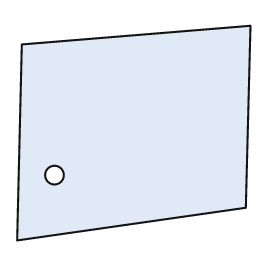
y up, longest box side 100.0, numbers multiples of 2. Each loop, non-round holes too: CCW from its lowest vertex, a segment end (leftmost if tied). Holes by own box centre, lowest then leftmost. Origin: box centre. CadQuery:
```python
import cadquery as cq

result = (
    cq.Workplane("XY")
    .moveTo(-50.0, -46.0)
    .lineTo(48.0, -32.0)
    .lineTo(50.0, 46.0)
    .lineTo(-48.0, 38.0)
    .close()
    .moveTo(-34.0, -18.0)
    .circle(4.0)
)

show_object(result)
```